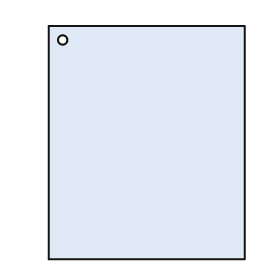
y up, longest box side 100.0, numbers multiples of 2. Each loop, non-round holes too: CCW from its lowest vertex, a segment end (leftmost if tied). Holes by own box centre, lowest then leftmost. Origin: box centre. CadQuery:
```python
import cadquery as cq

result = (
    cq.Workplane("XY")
    .moveTo(-42.0, -50.0)
    .lineTo(42.0, -50.0)
    .lineTo(42.0, 50.0)
    .lineTo(-42.0, 50.0)
    .close()
    .moveTo(-36.0, 44.0)
    .circle(2.0)
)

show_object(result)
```